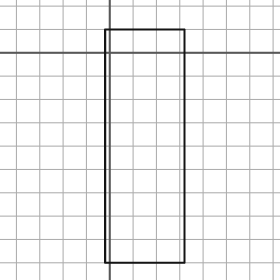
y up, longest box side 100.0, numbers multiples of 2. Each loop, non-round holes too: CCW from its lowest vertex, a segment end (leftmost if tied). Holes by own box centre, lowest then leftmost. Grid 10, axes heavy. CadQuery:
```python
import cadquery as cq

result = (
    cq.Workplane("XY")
    .moveTo(-2.0, -90.0)
    .lineTo(32.0, -90.0)
    .lineTo(32.0, 10.0)
    .lineTo(-2.0, 10.0)
    .close()
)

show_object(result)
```